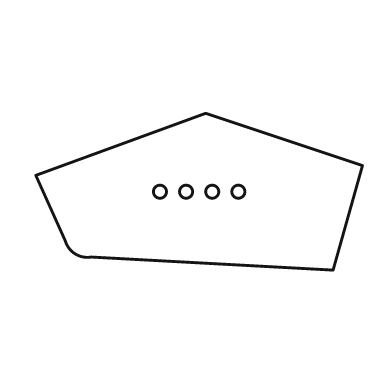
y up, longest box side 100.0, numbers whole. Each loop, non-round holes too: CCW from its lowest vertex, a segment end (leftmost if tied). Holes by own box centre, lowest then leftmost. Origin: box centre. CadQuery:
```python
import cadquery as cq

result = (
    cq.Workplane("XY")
    .moveTo(41.0, -24.0)
    .lineTo(50.0, 8.0)
    .lineTo(2.0, 24.0)
    .lineTo(-50.0, 5.0)
    .lineTo(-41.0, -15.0)
    .threePointArc((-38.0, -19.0), (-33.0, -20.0))
    .close()
    .moveTo(-12.0, 0.0)
    .circle(2.0)
    .moveTo(-4.0, 0.0)
    .circle(2.0)
    .moveTo(4.0, 0.0)
    .circle(2.0)
    .moveTo(12.0, 0.0)
    .circle(2.0)
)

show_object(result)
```